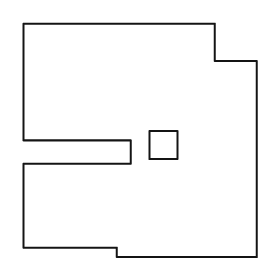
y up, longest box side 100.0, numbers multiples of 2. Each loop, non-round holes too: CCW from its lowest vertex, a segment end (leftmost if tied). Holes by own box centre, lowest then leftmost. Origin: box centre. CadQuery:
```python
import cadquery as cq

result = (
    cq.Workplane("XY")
    .moveTo(-10.0, -50.0)
    .lineTo(50.0, -50.0)
    .lineTo(50.0, 34.0)
    .lineTo(32.0, 34.0)
    .lineTo(32.0, 50.0)
    .lineTo(-50.0, 50.0)
    .lineTo(-50.0, 0.0)
    .lineTo(-4.0, 0.0)
    .lineTo(-4.0, -10.0)
    .lineTo(-50.0, -10.0)
    .lineTo(-50.0, -46.0)
    .lineTo(-10.0, -46.0)
    .close()
    .moveTo(4.0, -8.0)
    .lineTo(16.0, -8.0)
    .lineTo(16.0, 4.0)
    .lineTo(4.0, 4.0)
    .close()
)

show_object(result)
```